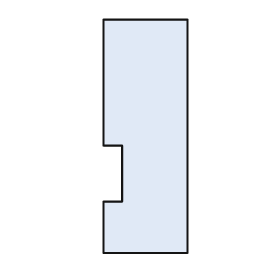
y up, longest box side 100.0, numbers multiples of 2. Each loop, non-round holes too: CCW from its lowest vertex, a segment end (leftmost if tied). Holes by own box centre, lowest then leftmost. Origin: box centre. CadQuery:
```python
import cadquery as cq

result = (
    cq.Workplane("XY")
    .moveTo(-18.0, -50.0)
    .lineTo(18.0, -50.0)
    .lineTo(18.0, 50.0)
    .lineTo(-18.0, 50.0)
    .lineTo(-18.0, -4.0)
    .lineTo(-10.0, -4.0)
    .lineTo(-10.0, -28.0)
    .lineTo(-18.0, -28.0)
    .close()
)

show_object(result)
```